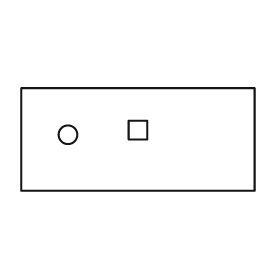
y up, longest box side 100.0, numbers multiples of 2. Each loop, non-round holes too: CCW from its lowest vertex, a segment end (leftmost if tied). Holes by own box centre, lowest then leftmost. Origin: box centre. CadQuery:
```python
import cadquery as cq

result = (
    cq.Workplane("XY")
    .moveTo(-50.0, -22.0)
    .lineTo(50.0, -22.0)
    .lineTo(50.0, 22.0)
    .lineTo(-50.0, 22.0)
    .close()
    .moveTo(-30.0, 2.0)
    .circle(4.0)
    .moveTo(-4.0, 0.0)
    .lineTo(4.0, 0.0)
    .lineTo(4.0, 8.0)
    .lineTo(-4.0, 8.0)
    .close()
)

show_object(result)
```